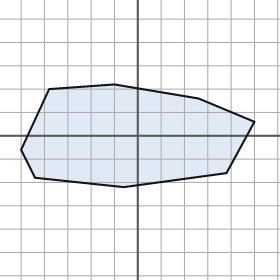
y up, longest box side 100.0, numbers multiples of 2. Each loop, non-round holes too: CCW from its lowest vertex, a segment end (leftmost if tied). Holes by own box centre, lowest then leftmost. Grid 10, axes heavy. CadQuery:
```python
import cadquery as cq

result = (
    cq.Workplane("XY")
    .moveTo(-6.0, -22.0)
    .lineTo(38.0, -16.0)
    .lineTo(50.0, 6.0)
    .lineTo(26.0, 16.0)
    .lineTo(-10.0, 22.0)
    .lineTo(-38.0, 20.0)
    .lineTo(-50.0, -6.0)
    .lineTo(-44.0, -18.0)
    .close()
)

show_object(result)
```